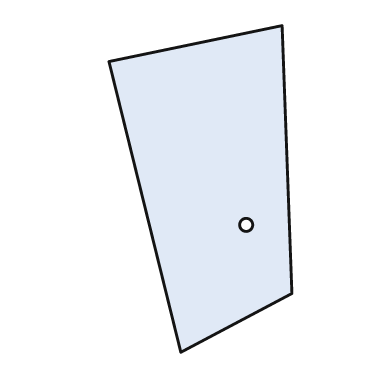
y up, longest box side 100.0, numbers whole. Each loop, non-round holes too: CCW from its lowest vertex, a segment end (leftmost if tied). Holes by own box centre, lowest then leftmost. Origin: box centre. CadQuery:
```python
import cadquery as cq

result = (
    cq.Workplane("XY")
    .moveTo(-6.0, -50.0)
    .lineTo(28.0, -32.0)
    .lineTo(25.0, 50.0)
    .lineTo(-28.0, 39.0)
    .close()
    .moveTo(14.0, -11.0)
    .circle(2.0)
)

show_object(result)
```